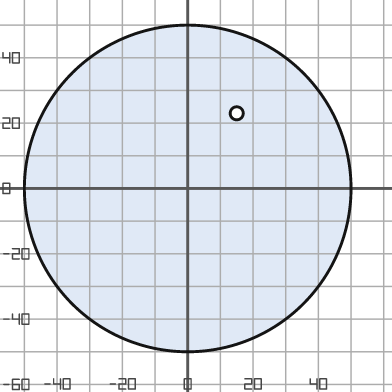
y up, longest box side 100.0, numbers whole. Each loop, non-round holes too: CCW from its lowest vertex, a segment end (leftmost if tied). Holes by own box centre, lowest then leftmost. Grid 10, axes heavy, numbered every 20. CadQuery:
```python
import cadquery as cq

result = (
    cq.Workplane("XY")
    .moveTo(0.0, 0.0)
    .circle(50.0)
    .moveTo(15.0, 23.0)
    .circle(2.0)
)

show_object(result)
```